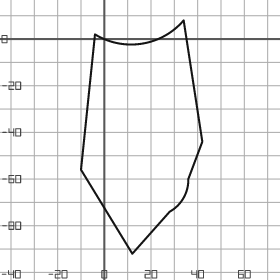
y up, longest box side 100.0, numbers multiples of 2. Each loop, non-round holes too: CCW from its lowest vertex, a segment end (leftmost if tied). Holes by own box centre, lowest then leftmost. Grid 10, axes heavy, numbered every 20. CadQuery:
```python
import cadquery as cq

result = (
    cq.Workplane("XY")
    .moveTo(12.0, -92.0)
    .lineTo(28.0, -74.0)
    .threePointArc((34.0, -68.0), (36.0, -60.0))
    .lineTo(42.0, -44.0)
    .lineTo(34.0, 8.0)
    .threePointArc((16.0, -2.0), (-4.0, 2.0))
    .lineTo(-10.0, -56.0)
    .close()
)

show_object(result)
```